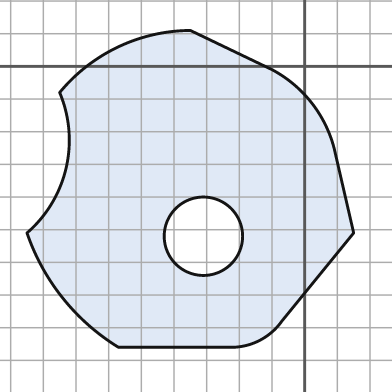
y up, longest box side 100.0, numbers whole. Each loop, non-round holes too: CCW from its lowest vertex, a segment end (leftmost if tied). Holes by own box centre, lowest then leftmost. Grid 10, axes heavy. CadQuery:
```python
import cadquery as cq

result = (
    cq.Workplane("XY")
    .moveTo(-57.0, -86.0)
    .lineTo(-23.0, -86.0)
    .threePointArc((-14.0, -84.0), (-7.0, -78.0))
    .lineTo(15.0, -51.0)
    .lineTo(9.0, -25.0)
    .threePointArc((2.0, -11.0), (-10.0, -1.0))
    .lineTo(-35.0, 11.0)
    .threePointArc((-57.0, 6.0), (-75.0, -8.0))
    .threePointArc((-73.0, -31.0), (-85.0, -51.0))
    .threePointArc((-74.0, -71.0), (-57.0, -86.0))
    .close()
    .moveTo(-31.0, -52.0)
    .circle(12.0)
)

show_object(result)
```